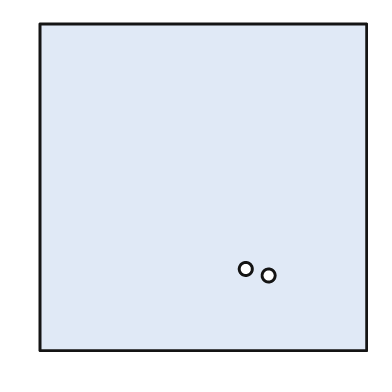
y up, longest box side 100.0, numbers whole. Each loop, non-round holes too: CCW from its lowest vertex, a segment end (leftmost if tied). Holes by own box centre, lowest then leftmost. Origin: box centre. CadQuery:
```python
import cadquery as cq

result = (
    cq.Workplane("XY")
    .moveTo(-50.0, -50.0)
    .lineTo(50.0, -50.0)
    .lineTo(50.0, 50.0)
    .lineTo(-50.0, 50.0)
    .close()
    .moveTo(20.0, -27.0)
    .circle(2.0)
    .moveTo(13.0, -25.0)
    .circle(2.0)
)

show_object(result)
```